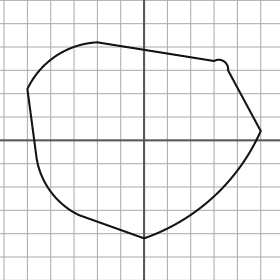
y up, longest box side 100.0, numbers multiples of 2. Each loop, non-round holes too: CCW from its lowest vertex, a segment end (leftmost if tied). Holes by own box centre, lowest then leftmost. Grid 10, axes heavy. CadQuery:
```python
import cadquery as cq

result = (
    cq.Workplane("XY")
    .moveTo(0.0, -42.0)
    .threePointArc((30.0, -24.0), (50.0, 4.0))
    .lineTo(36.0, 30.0)
    .threePointArc((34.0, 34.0), (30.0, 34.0))
    .lineTo(-20.0, 42.0)
    .threePointArc((-38.0, 36.0), (-50.0, 22.0))
    .lineTo(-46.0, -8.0)
    .threePointArc((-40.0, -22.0), (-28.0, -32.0))
    .close()
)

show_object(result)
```